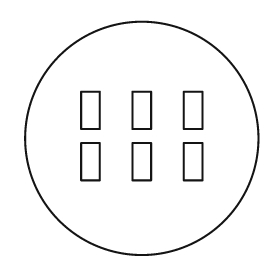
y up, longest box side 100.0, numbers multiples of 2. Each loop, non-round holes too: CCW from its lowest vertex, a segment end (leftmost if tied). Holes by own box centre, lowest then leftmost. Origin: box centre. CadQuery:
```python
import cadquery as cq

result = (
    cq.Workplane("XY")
    .moveTo(0.0, 0.0)
    .circle(50.0)
    .moveTo(-26.0, -18.0)
    .lineTo(-18.0, -18.0)
    .lineTo(-18.0, -2.0)
    .lineTo(-26.0, -2.0)
    .close()
    .moveTo(-4.0, -18.0)
    .lineTo(4.0, -18.0)
    .lineTo(4.0, -2.0)
    .lineTo(-4.0, -2.0)
    .close()
    .moveTo(18.0, -18.0)
    .lineTo(26.0, -18.0)
    .lineTo(26.0, -2.0)
    .lineTo(18.0, -2.0)
    .close()
    .moveTo(-26.0, 4.0)
    .lineTo(-18.0, 4.0)
    .lineTo(-18.0, 20.0)
    .lineTo(-26.0, 20.0)
    .close()
    .moveTo(-4.0, 4.0)
    .lineTo(4.0, 4.0)
    .lineTo(4.0, 20.0)
    .lineTo(-4.0, 20.0)
    .close()
    .moveTo(18.0, 4.0)
    .lineTo(26.0, 4.0)
    .lineTo(26.0, 20.0)
    .lineTo(18.0, 20.0)
    .close()
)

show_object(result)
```